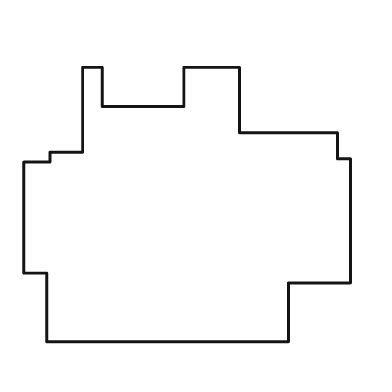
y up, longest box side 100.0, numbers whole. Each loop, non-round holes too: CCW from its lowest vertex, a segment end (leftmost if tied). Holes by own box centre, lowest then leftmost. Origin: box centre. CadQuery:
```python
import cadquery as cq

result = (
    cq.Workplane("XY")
    .moveTo(-43.0, -42.0)
    .lineTo(31.0, -42.0)
    .lineTo(31.0, -24.0)
    .lineTo(50.0, -24.0)
    .lineTo(50.0, 14.0)
    .lineTo(46.0, 14.0)
    .lineTo(46.0, 22.0)
    .lineTo(16.0, 22.0)
    .lineTo(16.0, 42.0)
    .lineTo(-1.0, 42.0)
    .lineTo(-1.0, 30.0)
    .lineTo(-26.0, 30.0)
    .lineTo(-26.0, 42.0)
    .lineTo(-32.0, 42.0)
    .lineTo(-32.0, 16.0)
    .lineTo(-42.0, 16.0)
    .lineTo(-42.0, 13.0)
    .lineTo(-50.0, 13.0)
    .lineTo(-50.0, -21.0)
    .lineTo(-43.0, -21.0)
    .close()
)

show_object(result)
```